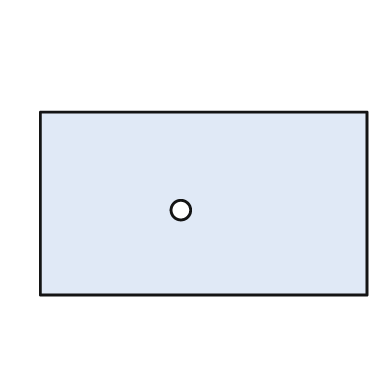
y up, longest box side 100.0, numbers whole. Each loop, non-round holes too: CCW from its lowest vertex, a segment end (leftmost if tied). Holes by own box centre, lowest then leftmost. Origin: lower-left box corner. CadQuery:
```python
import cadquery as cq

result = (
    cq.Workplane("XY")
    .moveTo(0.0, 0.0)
    .lineTo(100.0, 0.0)
    .lineTo(100.0, 56.0)
    .lineTo(0.0, 56.0)
    .close()
    .moveTo(43.0, 26.0)
    .circle(3.0)
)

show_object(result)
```